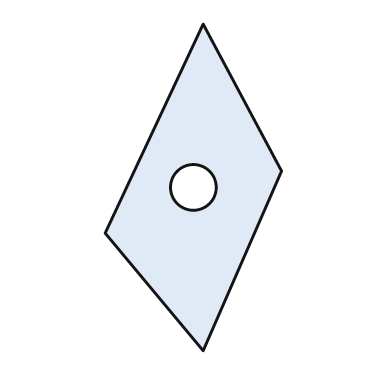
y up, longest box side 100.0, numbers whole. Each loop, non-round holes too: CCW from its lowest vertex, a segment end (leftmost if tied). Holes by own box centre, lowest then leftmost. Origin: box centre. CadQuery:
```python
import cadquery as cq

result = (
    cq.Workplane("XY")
    .moveTo(3.0, -50.0)
    .lineTo(27.0, 5.0)
    .lineTo(3.0, 50.0)
    .lineTo(-27.0, -14.0)
    .close()
    .moveTo(0.0, 0.0)
    .circle(7.0)
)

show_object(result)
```